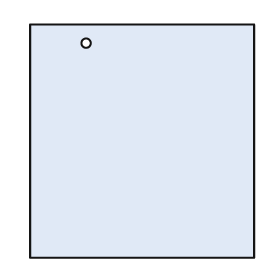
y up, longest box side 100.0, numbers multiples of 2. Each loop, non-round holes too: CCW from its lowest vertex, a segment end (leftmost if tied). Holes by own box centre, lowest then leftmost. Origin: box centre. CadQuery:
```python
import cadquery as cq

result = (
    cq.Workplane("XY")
    .moveTo(-48.0, -50.0)
    .lineTo(48.0, -50.0)
    .lineTo(48.0, 50.0)
    .lineTo(-48.0, 50.0)
    .close()
    .moveTo(-24.0, 42.0)
    .circle(2.0)
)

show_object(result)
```